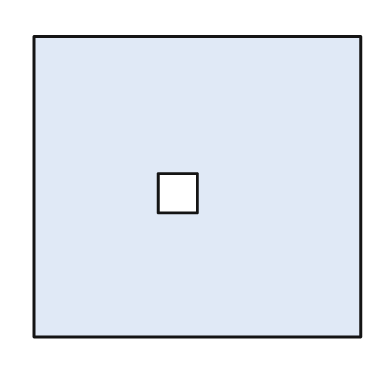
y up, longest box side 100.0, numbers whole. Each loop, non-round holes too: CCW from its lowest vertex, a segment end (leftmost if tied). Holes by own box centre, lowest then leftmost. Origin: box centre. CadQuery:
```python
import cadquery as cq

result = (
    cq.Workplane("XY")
    .moveTo(-50.0, -46.0)
    .lineTo(50.0, -46.0)
    .lineTo(50.0, 46.0)
    .lineTo(-50.0, 46.0)
    .close()
    .moveTo(-12.0, -8.0)
    .lineTo(0.0, -8.0)
    .lineTo(0.0, 4.0)
    .lineTo(-12.0, 4.0)
    .close()
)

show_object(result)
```